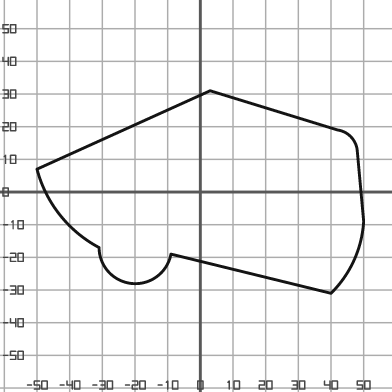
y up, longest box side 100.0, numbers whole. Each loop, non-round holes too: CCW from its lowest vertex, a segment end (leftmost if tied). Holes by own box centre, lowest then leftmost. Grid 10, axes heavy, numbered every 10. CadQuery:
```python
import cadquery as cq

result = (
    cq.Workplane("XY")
    .moveTo(40.0, -31.0)
    .threePointArc((47.0, -21.0), (50.0, -9.0))
    .lineTo(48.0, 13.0)
    .threePointArc((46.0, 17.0), (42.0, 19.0))
    .lineTo(3.0, 31.0)
    .lineTo(-50.0, 7.0)
    .threePointArc((-43.0, -7.0), (-31.0, -17.0))
    .threePointArc((-21.0, -28.0), (-9.0, -19.0))
    .close()
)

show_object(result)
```